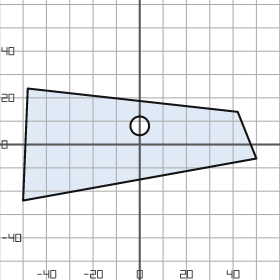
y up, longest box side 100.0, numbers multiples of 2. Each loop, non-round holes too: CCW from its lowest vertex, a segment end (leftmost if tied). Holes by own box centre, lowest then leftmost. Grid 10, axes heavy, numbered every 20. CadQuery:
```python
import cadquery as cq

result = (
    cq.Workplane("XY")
    .moveTo(-50.0, -24.0)
    .lineTo(50.0, -6.0)
    .lineTo(42.0, 14.0)
    .lineTo(-48.0, 24.0)
    .close()
    .moveTo(0.0, 8.0)
    .circle(4.0)
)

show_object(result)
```